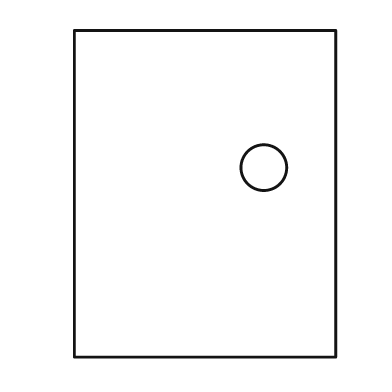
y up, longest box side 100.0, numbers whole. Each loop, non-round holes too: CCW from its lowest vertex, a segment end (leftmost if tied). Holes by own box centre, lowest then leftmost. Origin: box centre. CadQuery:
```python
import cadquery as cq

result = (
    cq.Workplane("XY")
    .moveTo(-40.0, -50.0)
    .lineTo(40.0, -50.0)
    .lineTo(40.0, 50.0)
    .lineTo(-40.0, 50.0)
    .close()
    .moveTo(18.0, 8.0)
    .circle(7.0)
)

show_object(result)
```